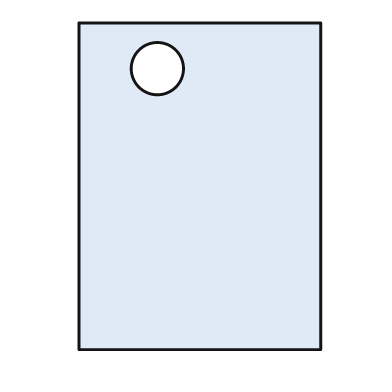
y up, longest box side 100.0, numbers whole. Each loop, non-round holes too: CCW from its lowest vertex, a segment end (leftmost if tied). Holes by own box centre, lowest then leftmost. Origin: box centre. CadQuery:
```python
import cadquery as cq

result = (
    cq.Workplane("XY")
    .moveTo(-37.0, -50.0)
    .lineTo(37.0, -50.0)
    .lineTo(37.0, 50.0)
    .lineTo(-37.0, 50.0)
    .close()
    .moveTo(-13.0, 36.0)
    .circle(8.0)
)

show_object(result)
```